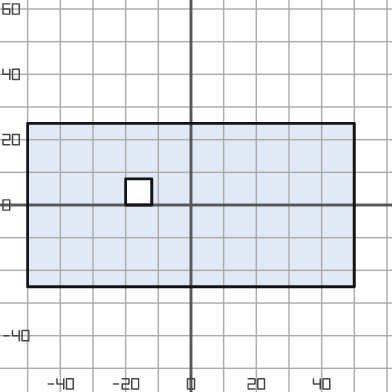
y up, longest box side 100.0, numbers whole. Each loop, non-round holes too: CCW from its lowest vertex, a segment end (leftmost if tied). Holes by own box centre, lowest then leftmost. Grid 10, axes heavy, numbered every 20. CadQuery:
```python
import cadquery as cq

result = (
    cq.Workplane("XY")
    .moveTo(-50.0, -25.0)
    .lineTo(50.0, -25.0)
    .lineTo(50.0, 25.0)
    .lineTo(-50.0, 25.0)
    .close()
    .moveTo(-20.0, 0.0)
    .lineTo(-12.0, 0.0)
    .lineTo(-12.0, 8.0)
    .lineTo(-20.0, 8.0)
    .close()
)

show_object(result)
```